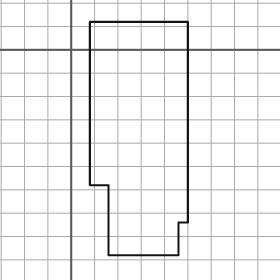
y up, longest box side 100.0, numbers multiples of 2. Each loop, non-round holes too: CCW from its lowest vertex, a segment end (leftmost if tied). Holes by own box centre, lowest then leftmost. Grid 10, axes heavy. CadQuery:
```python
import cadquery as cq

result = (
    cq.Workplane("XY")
    .moveTo(16.0, -88.0)
    .lineTo(46.0, -88.0)
    .lineTo(46.0, -74.0)
    .lineTo(50.0, -74.0)
    .lineTo(50.0, 12.0)
    .lineTo(8.0, 12.0)
    .lineTo(8.0, -58.0)
    .lineTo(16.0, -58.0)
    .close()
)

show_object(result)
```